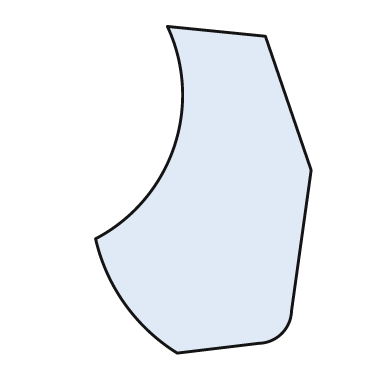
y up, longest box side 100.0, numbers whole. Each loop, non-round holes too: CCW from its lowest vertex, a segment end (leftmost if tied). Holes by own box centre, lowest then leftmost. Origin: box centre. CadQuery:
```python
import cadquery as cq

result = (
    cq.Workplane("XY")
    .moveTo(-8.0, -50.0)
    .lineTo(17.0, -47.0)
    .threePointArc((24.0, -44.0), (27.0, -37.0))
    .lineTo(33.0, 6.0)
    .lineTo(19.0, 47.0)
    .lineTo(-11.0, 50.0)
    .threePointArc((-9.0, 13.0), (-33.0, -15.0))
    .threePointArc((-24.0, -35.0), (-8.0, -50.0))
    .close()
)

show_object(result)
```